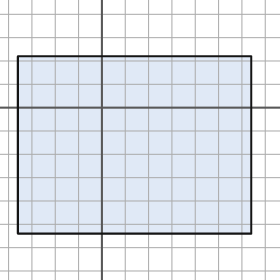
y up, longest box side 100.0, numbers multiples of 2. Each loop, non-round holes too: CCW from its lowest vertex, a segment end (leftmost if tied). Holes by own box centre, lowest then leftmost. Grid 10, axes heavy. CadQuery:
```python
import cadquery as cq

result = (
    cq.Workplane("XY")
    .moveTo(-36.0, -54.0)
    .lineTo(64.0, -54.0)
    .lineTo(64.0, 22.0)
    .lineTo(-36.0, 22.0)
    .close()
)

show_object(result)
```